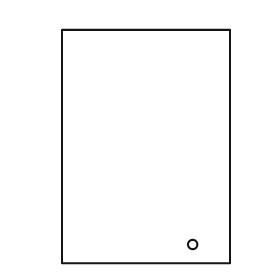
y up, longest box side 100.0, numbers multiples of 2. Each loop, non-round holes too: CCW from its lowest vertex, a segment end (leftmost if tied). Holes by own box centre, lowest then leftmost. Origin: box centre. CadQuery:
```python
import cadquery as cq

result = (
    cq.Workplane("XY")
    .moveTo(-36.0, -50.0)
    .lineTo(36.0, -50.0)
    .lineTo(36.0, 50.0)
    .lineTo(-36.0, 50.0)
    .close()
    .moveTo(20.0, -42.0)
    .circle(2.0)
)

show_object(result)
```